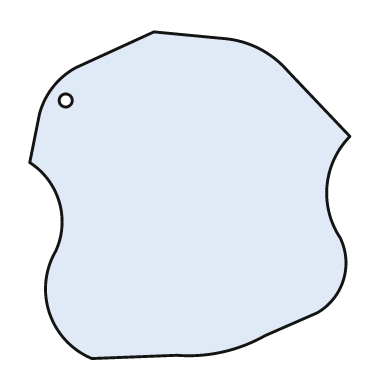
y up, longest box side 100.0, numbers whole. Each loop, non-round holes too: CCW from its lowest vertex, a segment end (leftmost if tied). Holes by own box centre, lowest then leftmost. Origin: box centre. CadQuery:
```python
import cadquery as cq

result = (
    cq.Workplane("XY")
    .moveTo(-30.0, -50.0)
    .lineTo(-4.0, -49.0)
    .threePointArc((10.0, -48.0), (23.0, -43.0))
    .lineTo(39.0, -36.0)
    .threePointArc((47.0, -26.0), (46.0, -13.0))
    .threePointArc((42.0, 3.0), (49.0, 18.0))
    .lineTo(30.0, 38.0)
    .threePointArc((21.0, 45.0), (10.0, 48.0))
    .lineTo(-11.0, 50.0)
    .lineTo(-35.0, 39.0)
    .threePointArc((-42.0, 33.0), (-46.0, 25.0))
    .lineTo(-49.0, 10.0)
    .threePointArc((-40.0, -2.0), (-41.0, -17.0))
    .threePointArc((-43.0, -36.0), (-30.0, -50.0))
    .close()
    .moveTo(-38.0, 29.0)
    .circle(2.0)
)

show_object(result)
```